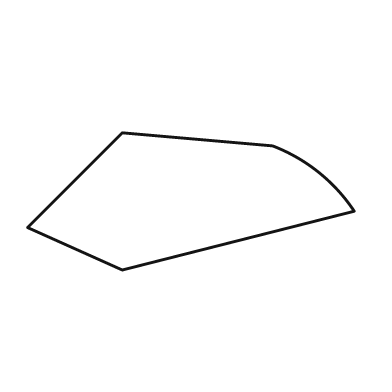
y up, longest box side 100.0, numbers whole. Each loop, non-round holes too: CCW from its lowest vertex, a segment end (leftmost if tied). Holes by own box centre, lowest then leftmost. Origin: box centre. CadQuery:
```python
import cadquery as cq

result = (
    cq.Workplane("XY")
    .moveTo(-21.0, -21.0)
    .lineTo(50.0, -3.0)
    .threePointArc((39.0, 9.0), (25.0, 17.0))
    .lineTo(-21.0, 21.0)
    .lineTo(-50.0, -8.0)
    .close()
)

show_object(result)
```